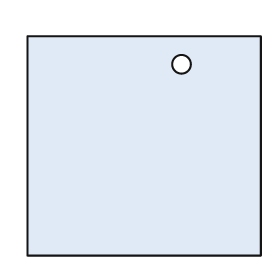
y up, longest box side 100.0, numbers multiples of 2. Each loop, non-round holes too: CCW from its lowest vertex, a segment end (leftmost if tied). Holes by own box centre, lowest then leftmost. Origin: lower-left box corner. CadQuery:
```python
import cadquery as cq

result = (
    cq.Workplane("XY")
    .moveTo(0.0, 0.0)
    .lineTo(100.0, 0.0)
    .lineTo(100.0, 94.0)
    .lineTo(0.0, 94.0)
    .close()
    .moveTo(66.0, 82.0)
    .circle(4.0)
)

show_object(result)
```